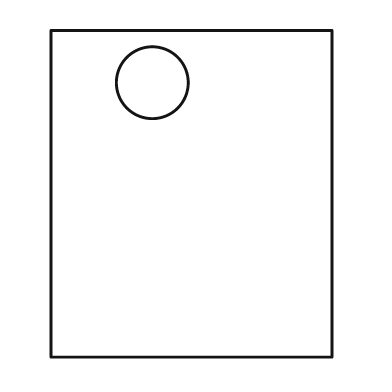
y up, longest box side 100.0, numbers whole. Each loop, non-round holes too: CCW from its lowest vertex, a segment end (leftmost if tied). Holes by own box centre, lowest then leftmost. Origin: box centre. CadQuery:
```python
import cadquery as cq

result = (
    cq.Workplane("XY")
    .moveTo(-43.0, -50.0)
    .lineTo(43.0, -50.0)
    .lineTo(43.0, 50.0)
    .lineTo(-43.0, 50.0)
    .close()
    .moveTo(-12.0, 34.0)
    .circle(11.0)
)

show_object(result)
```